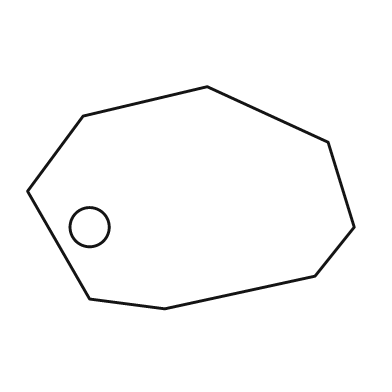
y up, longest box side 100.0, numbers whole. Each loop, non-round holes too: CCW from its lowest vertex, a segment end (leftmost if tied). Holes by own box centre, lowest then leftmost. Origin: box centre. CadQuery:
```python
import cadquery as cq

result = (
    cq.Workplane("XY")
    .moveTo(-8.0, -34.0)
    .lineTo(38.0, -24.0)
    .lineTo(50.0, -9.0)
    .lineTo(42.0, 17.0)
    .lineTo(5.0, 34.0)
    .lineTo(-33.0, 25.0)
    .lineTo(-50.0, 2.0)
    .lineTo(-31.0, -31.0)
    .close()
    .moveTo(-31.0, -9.0)
    .circle(6.0)
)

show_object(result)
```